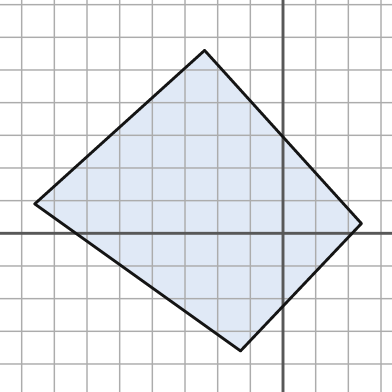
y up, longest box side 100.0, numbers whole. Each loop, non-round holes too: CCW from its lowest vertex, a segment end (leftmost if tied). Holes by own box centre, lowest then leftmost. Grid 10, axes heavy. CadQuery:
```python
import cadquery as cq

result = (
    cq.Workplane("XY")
    .moveTo(-13.0, -36.0)
    .lineTo(24.0, 3.0)
    .lineTo(-24.0, 56.0)
    .lineTo(-76.0, 9.0)
    .close()
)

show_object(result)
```